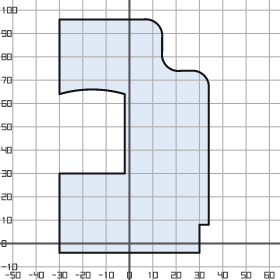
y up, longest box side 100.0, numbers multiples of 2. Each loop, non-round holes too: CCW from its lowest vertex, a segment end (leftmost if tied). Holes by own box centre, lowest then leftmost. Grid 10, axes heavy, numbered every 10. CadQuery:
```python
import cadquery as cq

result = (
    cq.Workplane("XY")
    .moveTo(-30.0, -4.0)
    .lineTo(30.0, -4.0)
    .lineTo(30.0, 8.0)
    .lineTo(34.0, 8.0)
    .lineTo(34.0, 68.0)
    .threePointArc((32.0, 72.0), (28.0, 74.0))
    .lineTo(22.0, 74.0)
    .threePointArc((16.0, 76.0), (14.0, 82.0))
    .lineTo(14.0, 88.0)
    .threePointArc((12.0, 94.0), (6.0, 96.0))
    .lineTo(-30.0, 96.0)
    .lineTo(-30.0, 64.0)
    .threePointArc((-16.0, 66.0), (-2.0, 64.0))
    .lineTo(-2.0, 30.0)
    .lineTo(-30.0, 30.0)
    .close()
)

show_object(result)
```